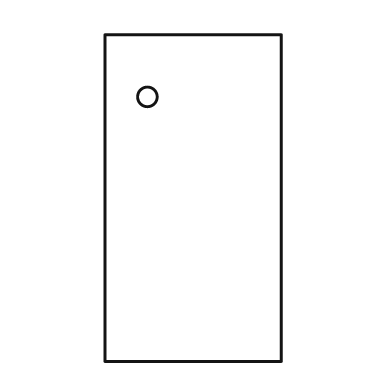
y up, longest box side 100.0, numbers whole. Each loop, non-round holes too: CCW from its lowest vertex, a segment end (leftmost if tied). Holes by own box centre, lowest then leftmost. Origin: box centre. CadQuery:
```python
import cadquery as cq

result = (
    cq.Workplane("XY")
    .moveTo(-27.0, -50.0)
    .lineTo(27.0, -50.0)
    .lineTo(27.0, 50.0)
    .lineTo(-27.0, 50.0)
    .close()
    .moveTo(-14.0, 31.0)
    .circle(3.0)
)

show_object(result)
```